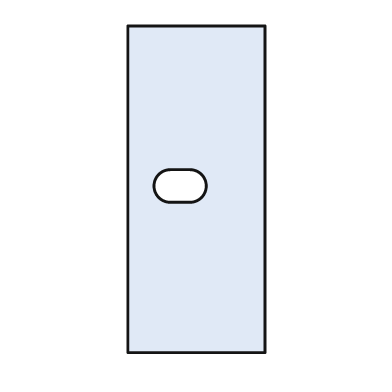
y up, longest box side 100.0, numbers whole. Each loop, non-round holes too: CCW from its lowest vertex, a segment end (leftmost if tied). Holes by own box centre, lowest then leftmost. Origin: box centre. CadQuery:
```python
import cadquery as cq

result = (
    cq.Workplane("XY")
    .moveTo(-21.0, -50.0)
    .lineTo(21.0, -50.0)
    .lineTo(21.0, 50.0)
    .lineTo(-21.0, 50.0)
    .close()
    .moveTo(-8.0, -4.0)
    .lineTo(-2.0, -4.0)
    .threePointArc((3.0, 1.0), (-2.0, 6.0))
    .lineTo(-8.0, 6.0)
    .threePointArc((-13.0, 1.0), (-8.0, -4.0))
    .close()
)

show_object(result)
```